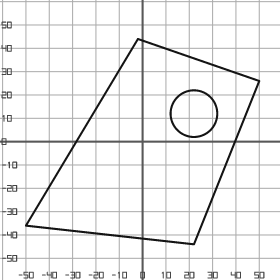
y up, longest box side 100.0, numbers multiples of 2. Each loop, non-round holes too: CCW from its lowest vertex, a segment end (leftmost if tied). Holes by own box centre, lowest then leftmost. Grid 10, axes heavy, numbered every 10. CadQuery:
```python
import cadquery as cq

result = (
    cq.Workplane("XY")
    .moveTo(22.0, -44.0)
    .lineTo(50.0, 26.0)
    .lineTo(-2.0, 44.0)
    .lineTo(-50.0, -36.0)
    .close()
    .moveTo(22.0, 12.0)
    .circle(10.0)
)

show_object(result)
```